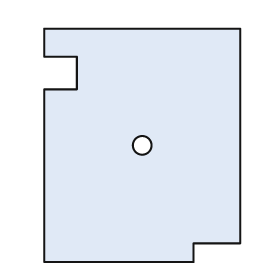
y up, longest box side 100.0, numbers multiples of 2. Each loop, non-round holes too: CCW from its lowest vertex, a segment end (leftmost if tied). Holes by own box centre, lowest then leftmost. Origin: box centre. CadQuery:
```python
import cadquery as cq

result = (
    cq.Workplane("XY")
    .moveTo(-42.0, -50.0)
    .lineTo(22.0, -50.0)
    .lineTo(22.0, -42.0)
    .lineTo(42.0, -42.0)
    .lineTo(42.0, 50.0)
    .lineTo(-42.0, 50.0)
    .lineTo(-42.0, 38.0)
    .lineTo(-28.0, 38.0)
    .lineTo(-28.0, 24.0)
    .lineTo(-42.0, 24.0)
    .close()
    .moveTo(0.0, 0.0)
    .circle(4.0)
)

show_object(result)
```